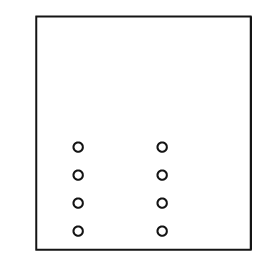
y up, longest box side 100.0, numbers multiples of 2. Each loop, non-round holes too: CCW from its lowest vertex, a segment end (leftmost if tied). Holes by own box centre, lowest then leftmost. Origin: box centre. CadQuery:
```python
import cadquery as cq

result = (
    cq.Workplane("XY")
    .moveTo(-46.0, -50.0)
    .lineTo(46.0, -50.0)
    .lineTo(46.0, 50.0)
    .lineTo(-46.0, 50.0)
    .close()
    .moveTo(-28.0, -42.0)
    .circle(2.0)
    .moveTo(8.0, -42.0)
    .circle(2.0)
    .moveTo(-28.0, -30.0)
    .circle(2.0)
    .moveTo(8.0, -30.0)
    .circle(2.0)
    .moveTo(-28.0, -18.0)
    .circle(2.0)
    .moveTo(8.0, -18.0)
    .circle(2.0)
    .moveTo(-28.0, -6.0)
    .circle(2.0)
    .moveTo(8.0, -6.0)
    .circle(2.0)
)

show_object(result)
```